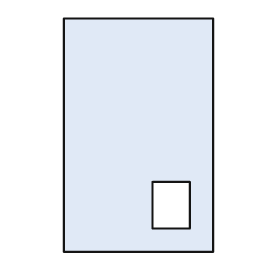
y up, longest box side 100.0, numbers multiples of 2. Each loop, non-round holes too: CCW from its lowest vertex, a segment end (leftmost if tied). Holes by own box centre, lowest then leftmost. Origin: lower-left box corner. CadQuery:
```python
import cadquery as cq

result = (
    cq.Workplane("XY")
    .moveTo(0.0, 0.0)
    .lineTo(64.0, 0.0)
    .lineTo(64.0, 100.0)
    .lineTo(0.0, 100.0)
    .close()
    .moveTo(38.0, 10.0)
    .lineTo(54.0, 10.0)
    .lineTo(54.0, 30.0)
    .lineTo(38.0, 30.0)
    .close()
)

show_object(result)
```